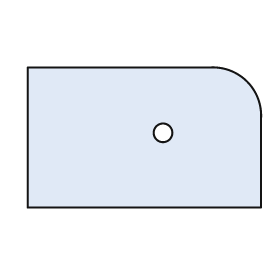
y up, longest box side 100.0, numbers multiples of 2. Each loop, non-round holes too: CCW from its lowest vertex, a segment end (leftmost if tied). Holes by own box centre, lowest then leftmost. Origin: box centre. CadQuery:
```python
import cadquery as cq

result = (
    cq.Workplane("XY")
    .moveTo(-50.0, -30.0)
    .lineTo(50.0, -30.0)
    .lineTo(50.0, 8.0)
    .threePointArc((44.0, 24.0), (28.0, 30.0))
    .lineTo(-50.0, 30.0)
    .close()
    .moveTo(8.0, 2.0)
    .circle(4.0)
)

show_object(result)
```